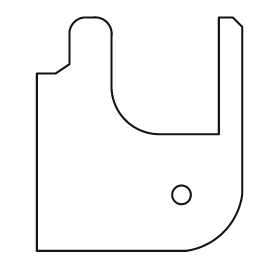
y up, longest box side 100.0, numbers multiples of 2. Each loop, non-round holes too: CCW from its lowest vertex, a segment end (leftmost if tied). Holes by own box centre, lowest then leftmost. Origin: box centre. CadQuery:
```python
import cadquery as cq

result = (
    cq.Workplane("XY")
    .moveTo(-44.0, -50.0)
    .lineTo(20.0, -50.0)
    .threePointArc((36.0, -42.0), (44.0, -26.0))
    .lineTo(44.0, 46.0)
    .lineTo(40.0, 50.0)
    .lineTo(34.0, 50.0)
    .lineTo(34.0, 0.0)
    .lineTo(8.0, 0.0)
    .threePointArc((-6.0, 6.0), (-12.0, 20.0))
    .lineTo(-12.0, 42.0)
    .threePointArc((-14.0, 48.0), (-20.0, 50.0))
    .lineTo(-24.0, 50.0)
    .threePointArc((-28.0, 48.0), (-30.0, 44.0))
    .lineTo(-30.0, 30.0)
    .lineTo(-36.0, 26.0)
    .lineTo(-44.0, 26.0)
    .close()
    .moveTo(18.0, -26.0)
    .circle(4.0)
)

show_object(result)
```